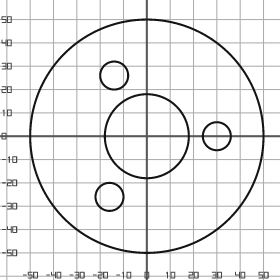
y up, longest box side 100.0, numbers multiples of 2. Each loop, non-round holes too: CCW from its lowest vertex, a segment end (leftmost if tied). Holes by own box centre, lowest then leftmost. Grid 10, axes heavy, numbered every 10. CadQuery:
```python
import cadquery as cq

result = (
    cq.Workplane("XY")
    .moveTo(0.0, 0.0)
    .circle(50.0)
    .moveTo(-16.0, -26.0)
    .circle(6.0)
    .moveTo(0.0, 0.0)
    .circle(18.0)
    .moveTo(30.0, 0.0)
    .circle(6.0)
    .moveTo(-14.0, 26.0)
    .circle(6.0)
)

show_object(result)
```